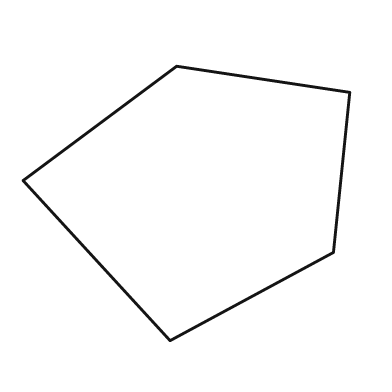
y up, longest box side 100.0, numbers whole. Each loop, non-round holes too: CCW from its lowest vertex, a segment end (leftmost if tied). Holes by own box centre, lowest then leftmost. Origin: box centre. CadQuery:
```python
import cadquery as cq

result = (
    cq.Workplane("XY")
    .moveTo(-5.0, -42.0)
    .lineTo(45.0, -15.0)
    .lineTo(50.0, 34.0)
    .lineTo(-3.0, 42.0)
    .lineTo(-50.0, 7.0)
    .close()
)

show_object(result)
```